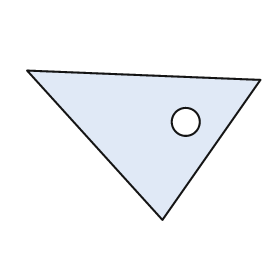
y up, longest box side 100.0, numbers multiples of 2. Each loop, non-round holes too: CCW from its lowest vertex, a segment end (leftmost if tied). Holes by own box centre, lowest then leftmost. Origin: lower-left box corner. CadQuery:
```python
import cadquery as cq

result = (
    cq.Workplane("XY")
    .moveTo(58.0, 0.0)
    .lineTo(100.0, 60.0)
    .lineTo(0.0, 64.0)
    .close()
    .moveTo(68.0, 42.0)
    .circle(6.0)
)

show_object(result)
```